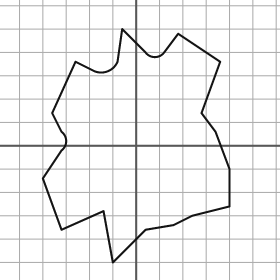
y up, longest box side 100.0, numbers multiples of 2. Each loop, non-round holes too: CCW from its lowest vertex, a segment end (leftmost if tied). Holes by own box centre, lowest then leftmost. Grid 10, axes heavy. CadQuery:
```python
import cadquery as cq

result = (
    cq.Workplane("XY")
    .moveTo(-10.0, -50.0)
    .lineTo(4.0, -36.0)
    .lineTo(16.0, -34.0)
    .lineTo(24.0, -30.0)
    .lineTo(40.0, -26.0)
    .lineTo(40.0, -10.0)
    .lineTo(34.0, 6.0)
    .lineTo(28.0, 14.0)
    .lineTo(36.0, 36.0)
    .lineTo(18.0, 48.0)
    .lineTo(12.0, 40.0)
    .threePointArc((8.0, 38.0), (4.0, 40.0))
    .lineTo(-6.0, 50.0)
    .lineTo(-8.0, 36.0)
    .threePointArc((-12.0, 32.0), (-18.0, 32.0))
    .lineTo(-26.0, 36.0)
    .lineTo(-36.0, 14.0)
    .lineTo(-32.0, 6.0)
    .threePointArc((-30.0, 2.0), (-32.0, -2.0))
    .lineTo(-40.0, -14.0)
    .lineTo(-32.0, -36.0)
    .lineTo(-14.0, -28.0)
    .close()
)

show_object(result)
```